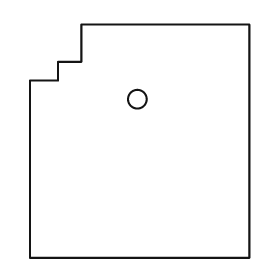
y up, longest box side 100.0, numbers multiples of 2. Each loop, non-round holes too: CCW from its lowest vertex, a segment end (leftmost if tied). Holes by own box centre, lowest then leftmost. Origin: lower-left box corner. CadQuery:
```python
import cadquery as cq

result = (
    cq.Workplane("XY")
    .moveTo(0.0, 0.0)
    .lineTo(94.0, 0.0)
    .lineTo(94.0, 100.0)
    .lineTo(22.0, 100.0)
    .lineTo(22.0, 84.0)
    .lineTo(12.0, 84.0)
    .lineTo(12.0, 76.0)
    .lineTo(0.0, 76.0)
    .close()
    .moveTo(46.0, 68.0)
    .circle(4.0)
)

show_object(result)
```